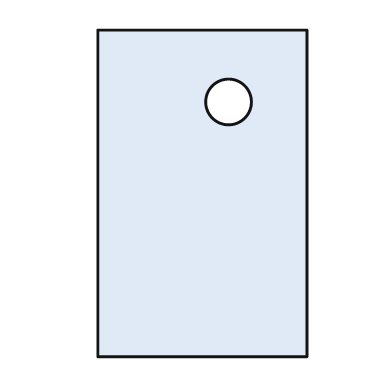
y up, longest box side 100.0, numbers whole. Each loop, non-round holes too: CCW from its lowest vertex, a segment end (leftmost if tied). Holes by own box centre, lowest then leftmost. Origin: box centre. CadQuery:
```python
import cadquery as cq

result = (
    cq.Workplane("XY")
    .moveTo(-32.0, -50.0)
    .lineTo(32.0, -50.0)
    .lineTo(32.0, 50.0)
    .lineTo(-32.0, 50.0)
    .close()
    .moveTo(8.0, 28.0)
    .circle(7.0)
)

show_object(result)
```